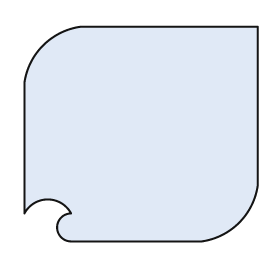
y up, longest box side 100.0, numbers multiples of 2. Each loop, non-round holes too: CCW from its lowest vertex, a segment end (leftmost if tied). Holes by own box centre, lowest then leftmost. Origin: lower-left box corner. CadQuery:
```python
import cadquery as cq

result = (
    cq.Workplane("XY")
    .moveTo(20.0, 0.0)
    .lineTo(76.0, 0.0)
    .threePointArc((92.0, 8.0), (100.0, 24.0))
    .lineTo(100.0, 92.0)
    .lineTo(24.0, 92.0)
    .threePointArc((8.0, 84.0), (0.0, 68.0))
    .lineTo(0.0, 12.0)
    .threePointArc((10.0, 18.0), (20.0, 12.0))
    .threePointArc((14.0, 6.0), (20.0, 0.0))
    .close()
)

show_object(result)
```